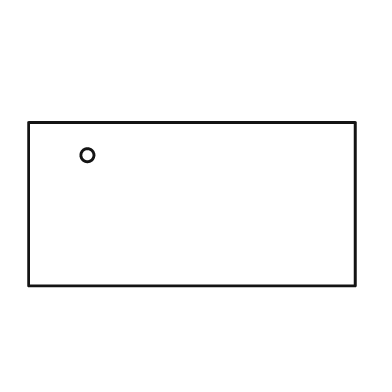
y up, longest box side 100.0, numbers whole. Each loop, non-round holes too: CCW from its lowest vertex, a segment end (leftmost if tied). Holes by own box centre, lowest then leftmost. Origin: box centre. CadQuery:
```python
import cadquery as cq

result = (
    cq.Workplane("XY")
    .moveTo(-50.0, -25.0)
    .lineTo(50.0, -25.0)
    .lineTo(50.0, 25.0)
    .lineTo(-50.0, 25.0)
    .close()
    .moveTo(-32.0, 15.0)
    .circle(2.0)
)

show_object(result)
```